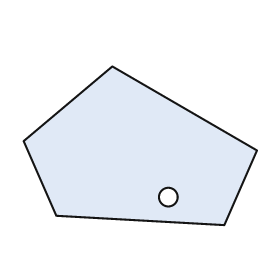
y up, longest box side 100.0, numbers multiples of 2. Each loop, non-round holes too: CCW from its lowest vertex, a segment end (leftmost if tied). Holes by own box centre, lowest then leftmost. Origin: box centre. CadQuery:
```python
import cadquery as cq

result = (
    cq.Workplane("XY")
    .moveTo(36.0, -34.0)
    .lineTo(50.0, -2.0)
    .lineTo(-12.0, 34.0)
    .lineTo(-50.0, 2.0)
    .lineTo(-36.0, -30.0)
    .close()
    .moveTo(12.0, -22.0)
    .circle(4.0)
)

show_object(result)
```